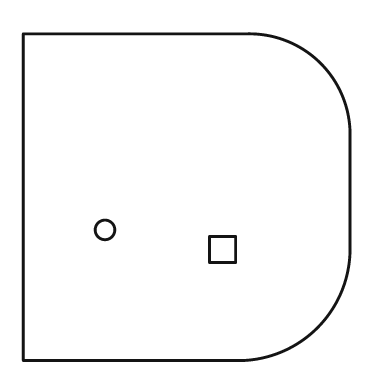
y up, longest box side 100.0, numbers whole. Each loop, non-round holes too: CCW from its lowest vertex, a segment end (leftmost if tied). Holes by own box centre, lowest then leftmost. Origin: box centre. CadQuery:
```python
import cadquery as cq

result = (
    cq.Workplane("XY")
    .moveTo(-50.0, -50.0)
    .lineTo(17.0, -50.0)
    .threePointArc((40.0, -40.0), (50.0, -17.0))
    .lineTo(50.0, 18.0)
    .threePointArc((41.0, 41.0), (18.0, 50.0))
    .lineTo(-50.0, 50.0)
    .close()
    .moveTo(7.0, -20.0)
    .lineTo(15.0, -20.0)
    .lineTo(15.0, -12.0)
    .lineTo(7.0, -12.0)
    .close()
    .moveTo(-25.0, -10.0)
    .circle(3.0)
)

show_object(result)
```